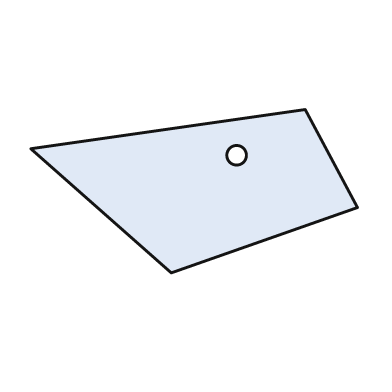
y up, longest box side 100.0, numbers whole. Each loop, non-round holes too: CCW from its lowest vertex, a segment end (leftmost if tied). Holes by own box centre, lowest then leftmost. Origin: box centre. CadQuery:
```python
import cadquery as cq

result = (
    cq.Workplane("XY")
    .moveTo(-7.0, -25.0)
    .lineTo(50.0, -5.0)
    .lineTo(34.0, 25.0)
    .lineTo(-50.0, 13.0)
    .close()
    .moveTo(13.0, 11.0)
    .circle(3.0)
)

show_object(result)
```